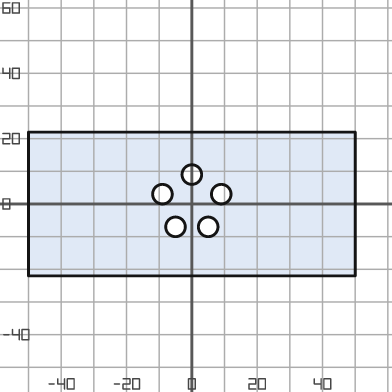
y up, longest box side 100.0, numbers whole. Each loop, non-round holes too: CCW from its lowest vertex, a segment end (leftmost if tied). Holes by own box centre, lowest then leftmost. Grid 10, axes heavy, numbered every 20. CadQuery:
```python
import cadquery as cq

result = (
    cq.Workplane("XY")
    .moveTo(-50.0, -22.0)
    .lineTo(50.0, -22.0)
    .lineTo(50.0, 22.0)
    .lineTo(-50.0, 22.0)
    .close()
    .moveTo(-5.0, -7.0)
    .circle(3.0)
    .moveTo(5.0, -7.0)
    .circle(3.0)
    .moveTo(-9.0, 3.0)
    .circle(3.0)
    .moveTo(9.0, 3.0)
    .circle(3.0)
    .moveTo(0.0, 9.0)
    .circle(3.0)
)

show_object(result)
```